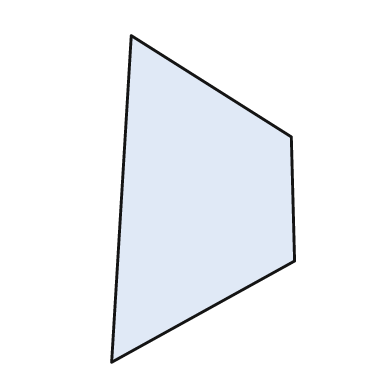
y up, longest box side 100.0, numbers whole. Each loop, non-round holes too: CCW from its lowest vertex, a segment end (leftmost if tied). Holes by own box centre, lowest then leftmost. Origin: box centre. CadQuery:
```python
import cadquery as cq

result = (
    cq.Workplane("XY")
    .moveTo(-28.0, -50.0)
    .lineTo(28.0, -19.0)
    .lineTo(27.0, 19.0)
    .lineTo(-22.0, 50.0)
    .close()
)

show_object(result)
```